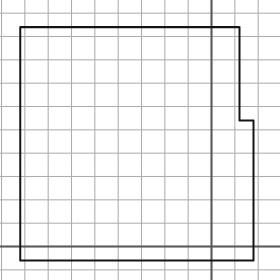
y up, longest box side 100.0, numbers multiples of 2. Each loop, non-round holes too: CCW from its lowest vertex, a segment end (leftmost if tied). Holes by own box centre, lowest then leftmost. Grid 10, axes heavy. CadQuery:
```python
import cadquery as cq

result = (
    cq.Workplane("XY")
    .moveTo(-82.0, -6.0)
    .lineTo(18.0, -6.0)
    .lineTo(18.0, 54.0)
    .lineTo(12.0, 54.0)
    .lineTo(12.0, 94.0)
    .lineTo(-82.0, 94.0)
    .close()
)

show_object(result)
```